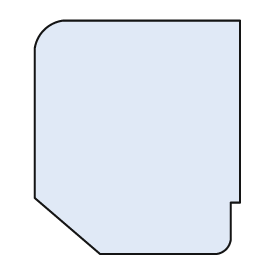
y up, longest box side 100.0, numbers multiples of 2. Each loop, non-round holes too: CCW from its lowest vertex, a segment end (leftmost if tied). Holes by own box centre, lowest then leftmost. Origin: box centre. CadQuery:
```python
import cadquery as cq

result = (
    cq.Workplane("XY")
    .moveTo(-16.0, -50.0)
    .lineTo(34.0, -50.0)
    .threePointArc((38.0, -48.0), (40.0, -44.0))
    .lineTo(40.0, -28.0)
    .lineTo(44.0, -28.0)
    .lineTo(44.0, 50.0)
    .lineTo(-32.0, 50.0)
    .threePointArc((-40.0, 46.0), (-44.0, 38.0))
    .lineTo(-44.0, -26.0)
    .close()
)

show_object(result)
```